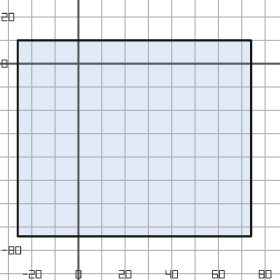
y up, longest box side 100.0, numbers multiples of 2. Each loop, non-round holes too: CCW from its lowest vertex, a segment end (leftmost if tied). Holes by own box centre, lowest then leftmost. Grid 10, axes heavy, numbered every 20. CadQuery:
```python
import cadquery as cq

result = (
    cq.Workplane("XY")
    .moveTo(-26.0, -74.0)
    .lineTo(74.0, -74.0)
    .lineTo(74.0, 10.0)
    .lineTo(-26.0, 10.0)
    .close()
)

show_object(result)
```